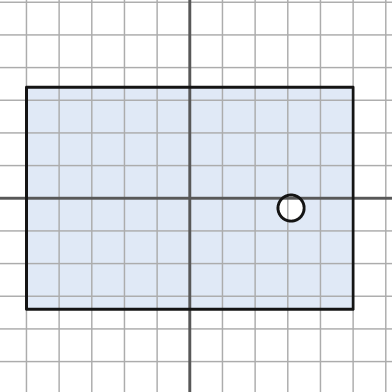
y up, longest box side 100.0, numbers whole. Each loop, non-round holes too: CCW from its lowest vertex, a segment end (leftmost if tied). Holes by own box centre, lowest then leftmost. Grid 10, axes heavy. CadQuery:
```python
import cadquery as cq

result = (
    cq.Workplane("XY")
    .moveTo(-50.0, -34.0)
    .lineTo(50.0, -34.0)
    .lineTo(50.0, 34.0)
    .lineTo(-50.0, 34.0)
    .close()
    .moveTo(31.0, -3.0)
    .circle(4.0)
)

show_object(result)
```